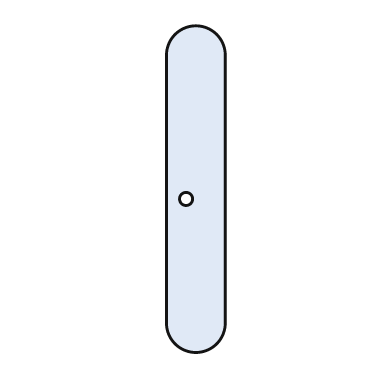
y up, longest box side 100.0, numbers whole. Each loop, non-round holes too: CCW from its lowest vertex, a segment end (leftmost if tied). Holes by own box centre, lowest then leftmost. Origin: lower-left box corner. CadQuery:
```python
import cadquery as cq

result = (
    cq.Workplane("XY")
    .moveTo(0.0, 9.0)
    .threePointArc((9.0, 0.0), (18.0, 9.0))
    .lineTo(18.0, 91.0)
    .threePointArc((9.0, 100.0), (0.0, 91.0))
    .close()
    .moveTo(6.0, 47.0)
    .circle(2.0)
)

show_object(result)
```